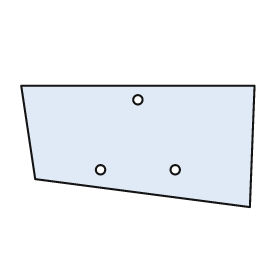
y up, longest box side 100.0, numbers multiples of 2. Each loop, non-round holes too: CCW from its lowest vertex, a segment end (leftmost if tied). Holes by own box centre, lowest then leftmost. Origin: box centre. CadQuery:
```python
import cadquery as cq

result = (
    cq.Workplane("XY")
    .moveTo(48.0, -26.0)
    .lineTo(50.0, 26.0)
    .lineTo(-50.0, 26.0)
    .lineTo(-44.0, -14.0)
    .close()
    .moveTo(-16.0, -10.0)
    .circle(2.0)
    .moveTo(16.0, -10.0)
    .circle(2.0)
    .moveTo(0.0, 20.0)
    .circle(2.0)
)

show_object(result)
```